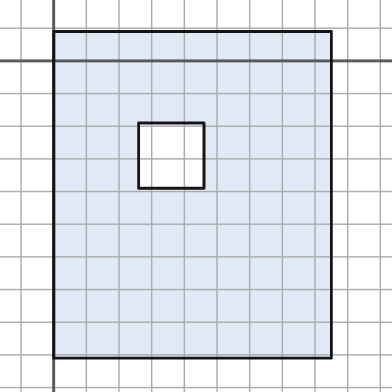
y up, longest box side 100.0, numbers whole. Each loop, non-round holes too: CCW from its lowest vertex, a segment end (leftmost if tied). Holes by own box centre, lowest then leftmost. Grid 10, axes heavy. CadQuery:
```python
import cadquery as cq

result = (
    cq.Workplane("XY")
    .moveTo(0.0, -91.0)
    .lineTo(85.0, -91.0)
    .lineTo(85.0, 9.0)
    .lineTo(0.0, 9.0)
    .close()
    .moveTo(26.0, -39.0)
    .lineTo(46.0, -39.0)
    .lineTo(46.0, -19.0)
    .lineTo(26.0, -19.0)
    .close()
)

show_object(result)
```